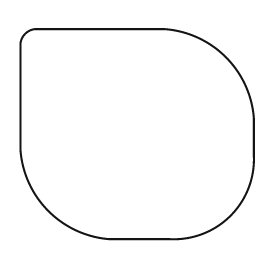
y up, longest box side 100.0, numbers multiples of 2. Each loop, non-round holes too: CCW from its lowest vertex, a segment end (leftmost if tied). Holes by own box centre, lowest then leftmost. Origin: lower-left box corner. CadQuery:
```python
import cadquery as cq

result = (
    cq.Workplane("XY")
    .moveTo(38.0, 0.0)
    .lineTo(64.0, 0.0)
    .threePointArc((90.0, 10.0), (100.0, 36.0))
    .lineTo(100.0, 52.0)
    .threePointArc((88.0, 78.0), (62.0, 90.0))
    .lineTo(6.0, 90.0)
    .threePointArc((2.0, 88.0), (0.0, 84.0))
    .lineTo(0.0, 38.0)
    .threePointArc((12.0, 12.0), (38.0, 0.0))
    .close()
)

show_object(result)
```